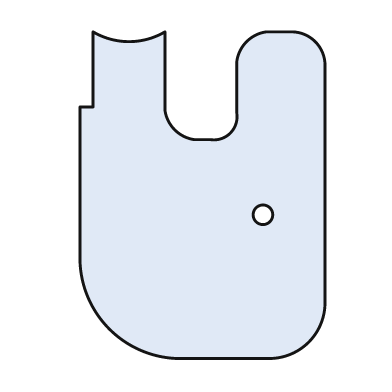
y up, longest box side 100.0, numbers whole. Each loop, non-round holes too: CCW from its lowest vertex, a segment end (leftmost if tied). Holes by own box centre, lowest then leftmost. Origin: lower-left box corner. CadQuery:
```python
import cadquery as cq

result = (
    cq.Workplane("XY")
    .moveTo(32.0, 0.0)
    .lineTo(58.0, 0.0)
    .threePointArc((70.0, 5.0), (75.0, 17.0))
    .lineTo(75.0, 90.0)
    .threePointArc((72.0, 97.0), (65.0, 100.0))
    .lineTo(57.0, 100.0)
    .threePointArc((51.0, 97.0), (48.0, 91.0))
    .lineTo(48.0, 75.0)
    .threePointArc((46.0, 69.0), (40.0, 67.0))
    .lineTo(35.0, 67.0)
    .threePointArc((29.0, 70.0), (26.0, 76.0))
    .lineTo(26.0, 100.0)
    .threePointArc((15.0, 97.0), (4.0, 100.0))
    .lineTo(4.0, 77.0)
    .lineTo(0.0, 77.0)
    .lineTo(0.0, 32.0)
    .threePointArc((9.0, 9.0), (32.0, 0.0))
    .close()
    .moveTo(56.0, 44.0)
    .circle(3.0)
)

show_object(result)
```